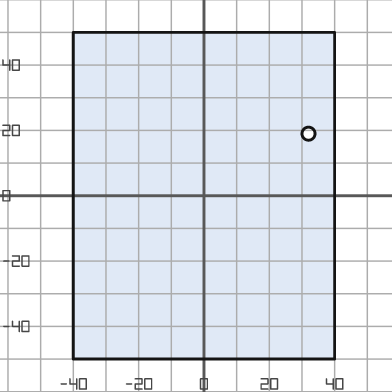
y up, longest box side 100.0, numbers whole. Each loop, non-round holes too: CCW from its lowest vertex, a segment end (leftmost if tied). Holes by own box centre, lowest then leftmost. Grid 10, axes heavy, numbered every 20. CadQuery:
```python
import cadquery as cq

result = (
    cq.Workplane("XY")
    .moveTo(-40.0, -50.0)
    .lineTo(40.0, -50.0)
    .lineTo(40.0, 50.0)
    .lineTo(-40.0, 50.0)
    .close()
    .moveTo(32.0, 19.0)
    .circle(2.0)
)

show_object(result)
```